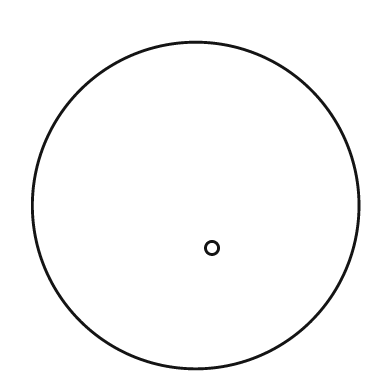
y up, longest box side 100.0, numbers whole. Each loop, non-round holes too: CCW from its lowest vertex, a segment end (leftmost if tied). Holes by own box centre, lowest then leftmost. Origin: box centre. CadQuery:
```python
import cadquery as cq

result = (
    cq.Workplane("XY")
    .moveTo(0.0, 0.0)
    .circle(50.0)
    .moveTo(5.0, -13.0)
    .circle(2.0)
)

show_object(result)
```